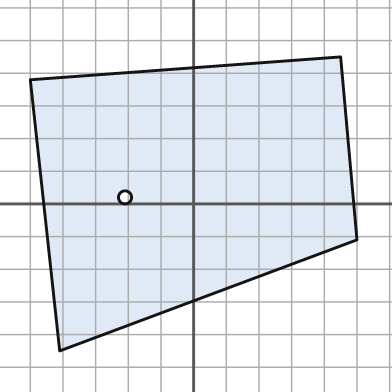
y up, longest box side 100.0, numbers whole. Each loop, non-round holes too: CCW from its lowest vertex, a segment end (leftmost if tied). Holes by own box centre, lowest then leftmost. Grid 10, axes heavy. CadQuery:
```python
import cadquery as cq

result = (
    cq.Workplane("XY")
    .moveTo(-41.0, -45.0)
    .lineTo(50.0, -11.0)
    .lineTo(45.0, 45.0)
    .lineTo(-50.0, 38.0)
    .close()
    .moveTo(-21.0, 2.0)
    .circle(2.0)
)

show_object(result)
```